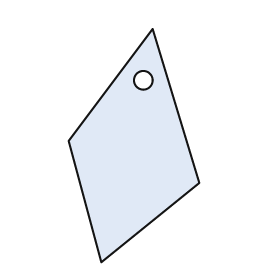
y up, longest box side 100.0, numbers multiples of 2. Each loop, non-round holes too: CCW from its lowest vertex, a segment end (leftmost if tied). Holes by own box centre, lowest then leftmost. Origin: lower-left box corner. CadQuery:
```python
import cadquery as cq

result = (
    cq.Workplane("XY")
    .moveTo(14.0, 0.0)
    .lineTo(56.0, 34.0)
    .lineTo(36.0, 100.0)
    .lineTo(0.0, 52.0)
    .close()
    .moveTo(32.0, 78.0)
    .circle(4.0)
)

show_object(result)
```